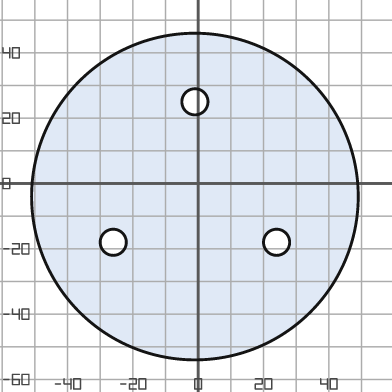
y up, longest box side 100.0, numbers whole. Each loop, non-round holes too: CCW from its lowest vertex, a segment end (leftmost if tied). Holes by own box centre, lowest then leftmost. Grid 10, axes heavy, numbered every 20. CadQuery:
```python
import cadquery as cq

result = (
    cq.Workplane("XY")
    .moveTo(-1.0, -4.0)
    .circle(50.0)
    .moveTo(-26.0, -18.0)
    .circle(4.0)
    .moveTo(24.0, -18.0)
    .circle(4.0)
    .moveTo(-1.0, 25.0)
    .circle(4.0)
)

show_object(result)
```